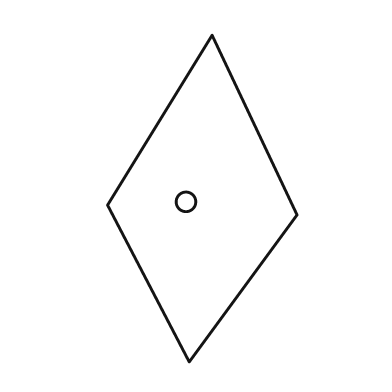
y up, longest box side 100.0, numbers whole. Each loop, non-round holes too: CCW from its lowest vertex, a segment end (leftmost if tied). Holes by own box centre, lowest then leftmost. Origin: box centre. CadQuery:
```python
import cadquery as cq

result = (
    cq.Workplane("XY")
    .moveTo(-4.0, -50.0)
    .lineTo(29.0, -5.0)
    .lineTo(3.0, 50.0)
    .lineTo(-29.0, -2.0)
    .close()
    .moveTo(-5.0, -1.0)
    .circle(3.0)
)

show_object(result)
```